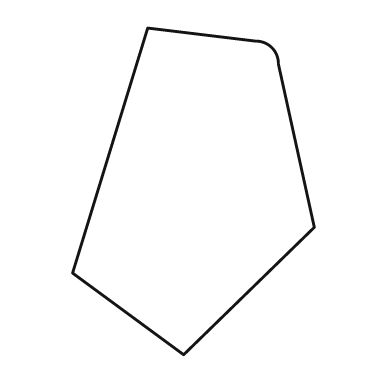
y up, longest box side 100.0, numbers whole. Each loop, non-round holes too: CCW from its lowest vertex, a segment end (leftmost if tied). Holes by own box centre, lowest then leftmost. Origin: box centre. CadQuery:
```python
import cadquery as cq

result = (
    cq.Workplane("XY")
    .moveTo(-3.0, -50.0)
    .lineTo(37.0, -11.0)
    .lineTo(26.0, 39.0)
    .threePointArc((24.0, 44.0), (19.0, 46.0))
    .lineTo(-14.0, 50.0)
    .lineTo(-37.0, -25.0)
    .close()
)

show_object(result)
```